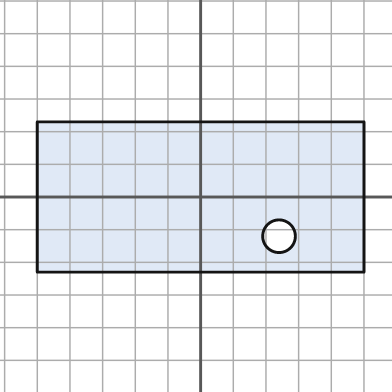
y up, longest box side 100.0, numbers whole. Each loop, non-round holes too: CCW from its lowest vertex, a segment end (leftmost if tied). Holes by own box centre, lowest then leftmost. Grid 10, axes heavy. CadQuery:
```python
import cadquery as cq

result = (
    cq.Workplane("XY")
    .moveTo(-50.0, -23.0)
    .lineTo(50.0, -23.0)
    .lineTo(50.0, 23.0)
    .lineTo(-50.0, 23.0)
    .close()
    .moveTo(24.0, -12.0)
    .circle(5.0)
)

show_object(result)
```